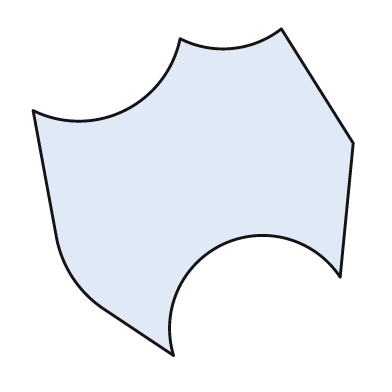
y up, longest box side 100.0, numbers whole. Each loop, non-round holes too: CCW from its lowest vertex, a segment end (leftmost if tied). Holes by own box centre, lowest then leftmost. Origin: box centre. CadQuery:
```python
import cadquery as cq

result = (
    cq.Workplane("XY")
    .moveTo(-6.0, -50.0)
    .threePointArc((9.0, -16.0), (45.0, -26.0))
    .lineTo(49.0, 15.0)
    .lineTo(27.0, 50.0)
    .threePointArc((12.0, 44.0), (-4.0, 47.0))
    .threePointArc((-21.0, 25.0), (-49.0, 25.0))
    .lineTo(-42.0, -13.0)
    .threePointArc((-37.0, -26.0), (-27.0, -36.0))
    .close()
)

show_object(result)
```